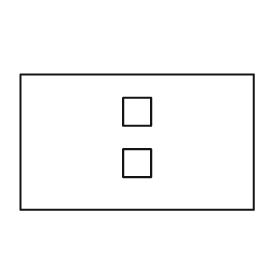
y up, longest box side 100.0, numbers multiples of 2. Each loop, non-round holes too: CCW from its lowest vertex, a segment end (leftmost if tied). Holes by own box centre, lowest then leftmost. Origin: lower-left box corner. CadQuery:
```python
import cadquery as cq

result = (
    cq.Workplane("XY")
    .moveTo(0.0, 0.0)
    .lineTo(100.0, 0.0)
    .lineTo(100.0, 58.0)
    .lineTo(0.0, 58.0)
    .close()
    .moveTo(44.0, 14.0)
    .lineTo(56.0, 14.0)
    .lineTo(56.0, 26.0)
    .lineTo(44.0, 26.0)
    .close()
    .moveTo(44.0, 36.0)
    .lineTo(56.0, 36.0)
    .lineTo(56.0, 48.0)
    .lineTo(44.0, 48.0)
    .close()
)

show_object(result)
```